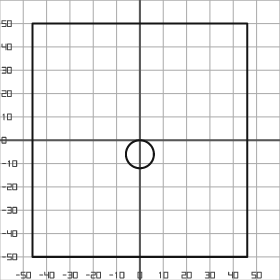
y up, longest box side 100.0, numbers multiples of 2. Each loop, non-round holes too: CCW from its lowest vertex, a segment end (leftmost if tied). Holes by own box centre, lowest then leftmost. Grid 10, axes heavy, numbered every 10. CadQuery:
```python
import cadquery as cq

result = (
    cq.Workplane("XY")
    .moveTo(-46.0, -50.0)
    .lineTo(46.0, -50.0)
    .lineTo(46.0, 50.0)
    .lineTo(-46.0, 50.0)
    .close()
    .moveTo(0.0, -6.0)
    .circle(6.0)
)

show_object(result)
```